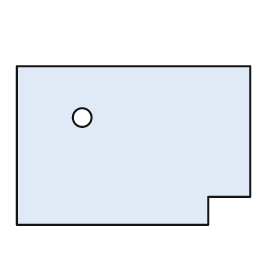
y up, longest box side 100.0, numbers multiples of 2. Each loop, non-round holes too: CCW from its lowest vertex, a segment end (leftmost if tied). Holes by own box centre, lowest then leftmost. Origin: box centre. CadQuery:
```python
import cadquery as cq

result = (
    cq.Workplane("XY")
    .moveTo(-50.0, -34.0)
    .lineTo(32.0, -34.0)
    .lineTo(32.0, -22.0)
    .lineTo(50.0, -22.0)
    .lineTo(50.0, 34.0)
    .lineTo(-50.0, 34.0)
    .close()
    .moveTo(-22.0, 12.0)
    .circle(4.0)
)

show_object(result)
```